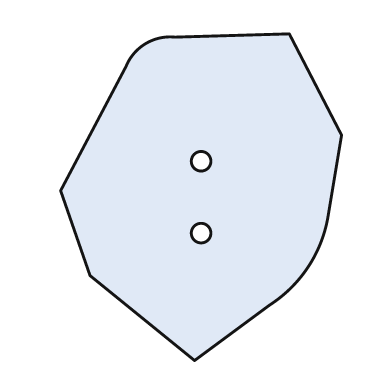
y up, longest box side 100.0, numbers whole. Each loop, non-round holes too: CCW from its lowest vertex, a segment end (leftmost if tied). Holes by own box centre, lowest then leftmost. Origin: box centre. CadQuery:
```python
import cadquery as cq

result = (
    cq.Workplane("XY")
    .moveTo(-2.0, -50.0)
    .lineTo(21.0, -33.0)
    .threePointArc((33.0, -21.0), (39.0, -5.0))
    .lineTo(43.0, 19.0)
    .lineTo(27.0, 50.0)
    .lineTo(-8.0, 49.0)
    .threePointArc((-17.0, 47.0), (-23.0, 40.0))
    .lineTo(-43.0, 2.0)
    .lineTo(-34.0, -24.0)
    .close()
    .moveTo(0.0, -11.0)
    .circle(3.0)
    .moveTo(0.0, 11.0)
    .circle(3.0)
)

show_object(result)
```